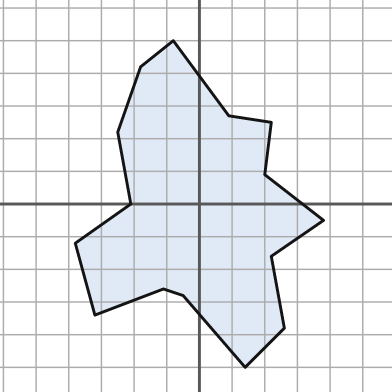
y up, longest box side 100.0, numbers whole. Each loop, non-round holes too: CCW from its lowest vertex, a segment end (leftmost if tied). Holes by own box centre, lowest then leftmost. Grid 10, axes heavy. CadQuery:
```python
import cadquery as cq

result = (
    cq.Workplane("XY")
    .moveTo(14.0, -50.0)
    .lineTo(26.0, -38.0)
    .lineTo(22.0, -16.0)
    .lineTo(38.0, -5.0)
    .lineTo(20.0, 9.0)
    .lineTo(22.0, 25.0)
    .lineTo(9.0, 27.0)
    .lineTo(-8.0, 50.0)
    .lineTo(-18.0, 42.0)
    .lineTo(-25.0, 22.0)
    .lineTo(-21.0, 0.0)
    .lineTo(-38.0, -12.0)
    .lineTo(-32.0, -34.0)
    .lineTo(-11.0, -26.0)
    .lineTo(-5.0, -28.0)
    .close()
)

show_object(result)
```